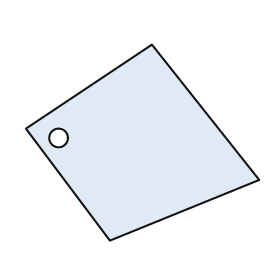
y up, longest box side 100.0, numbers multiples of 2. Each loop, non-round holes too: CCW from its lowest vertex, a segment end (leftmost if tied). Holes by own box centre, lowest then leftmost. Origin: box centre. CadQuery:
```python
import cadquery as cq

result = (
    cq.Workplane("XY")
    .moveTo(-14.0, -42.0)
    .lineTo(50.0, -16.0)
    .lineTo(4.0, 42.0)
    .lineTo(-50.0, 6.0)
    .close()
    .moveTo(-36.0, 2.0)
    .circle(4.0)
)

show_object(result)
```